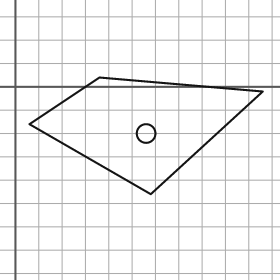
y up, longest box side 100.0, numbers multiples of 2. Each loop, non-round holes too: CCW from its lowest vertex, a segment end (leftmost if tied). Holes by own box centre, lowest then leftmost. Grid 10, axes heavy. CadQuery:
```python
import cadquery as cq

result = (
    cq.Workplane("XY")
    .moveTo(58.0, -46.0)
    .lineTo(106.0, -2.0)
    .lineTo(36.0, 4.0)
    .lineTo(6.0, -16.0)
    .close()
    .moveTo(56.0, -20.0)
    .circle(4.0)
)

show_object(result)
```